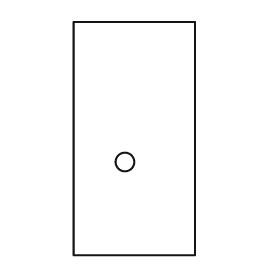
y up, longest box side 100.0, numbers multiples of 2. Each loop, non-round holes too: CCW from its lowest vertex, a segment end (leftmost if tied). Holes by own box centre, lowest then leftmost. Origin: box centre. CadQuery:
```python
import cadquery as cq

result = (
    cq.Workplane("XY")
    .moveTo(-26.0, -50.0)
    .lineTo(26.0, -50.0)
    .lineTo(26.0, 50.0)
    .lineTo(-26.0, 50.0)
    .close()
    .moveTo(-4.0, -10.0)
    .circle(4.0)
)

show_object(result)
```